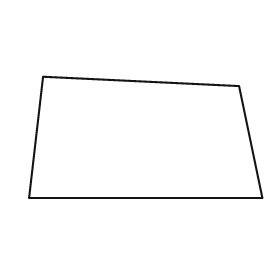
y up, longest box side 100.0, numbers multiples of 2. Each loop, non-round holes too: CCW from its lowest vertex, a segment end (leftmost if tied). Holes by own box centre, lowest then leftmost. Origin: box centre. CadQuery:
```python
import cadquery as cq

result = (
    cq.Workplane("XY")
    .moveTo(-50.0, -26.0)
    .lineTo(50.0, -26.0)
    .lineTo(40.0, 22.0)
    .lineTo(-44.0, 26.0)
    .close()
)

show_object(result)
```